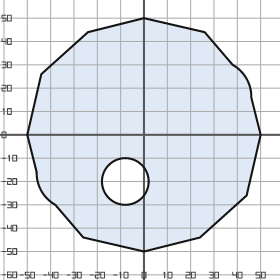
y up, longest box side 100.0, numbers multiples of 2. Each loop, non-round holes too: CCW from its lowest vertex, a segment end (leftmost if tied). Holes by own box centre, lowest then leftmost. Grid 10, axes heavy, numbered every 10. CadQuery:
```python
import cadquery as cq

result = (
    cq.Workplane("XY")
    .moveTo(0.0, -50.0)
    .lineTo(24.0, -44.0)
    .lineTo(44.0, -26.0)
    .lineTo(50.0, 0.0)
    .lineTo(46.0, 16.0)
    .threePointArc((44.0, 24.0), (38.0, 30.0))
    .lineTo(26.0, 44.0)
    .lineTo(0.0, 50.0)
    .lineTo(-24.0, 44.0)
    .lineTo(-44.0, 26.0)
    .lineTo(-50.0, 0.0)
    .lineTo(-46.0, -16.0)
    .threePointArc((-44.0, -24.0), (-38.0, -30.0))
    .lineTo(-26.0, -44.0)
    .close()
    .moveTo(-8.0, -20.0)
    .circle(10.0)
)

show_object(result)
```